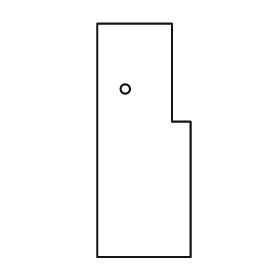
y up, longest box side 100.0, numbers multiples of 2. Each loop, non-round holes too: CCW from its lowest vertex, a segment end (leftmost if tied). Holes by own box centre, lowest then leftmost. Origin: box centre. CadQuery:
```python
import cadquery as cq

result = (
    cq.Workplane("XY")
    .moveTo(-20.0, -50.0)
    .lineTo(20.0, -50.0)
    .lineTo(20.0, 8.0)
    .lineTo(12.0, 8.0)
    .lineTo(12.0, 50.0)
    .lineTo(-20.0, 50.0)
    .close()
    .moveTo(-8.0, 22.0)
    .circle(2.0)
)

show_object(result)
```